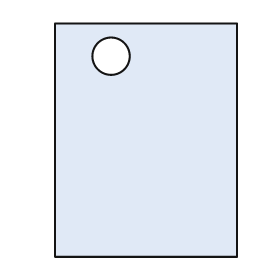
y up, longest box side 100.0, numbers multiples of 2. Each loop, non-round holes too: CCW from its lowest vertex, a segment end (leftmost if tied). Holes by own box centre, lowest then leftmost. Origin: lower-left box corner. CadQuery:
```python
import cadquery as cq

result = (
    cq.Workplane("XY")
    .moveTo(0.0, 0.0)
    .lineTo(78.0, 0.0)
    .lineTo(78.0, 100.0)
    .lineTo(0.0, 100.0)
    .close()
    .moveTo(24.0, 86.0)
    .circle(8.0)
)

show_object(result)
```